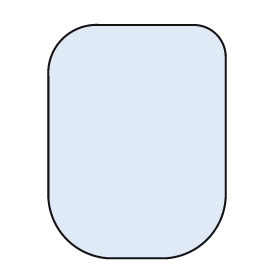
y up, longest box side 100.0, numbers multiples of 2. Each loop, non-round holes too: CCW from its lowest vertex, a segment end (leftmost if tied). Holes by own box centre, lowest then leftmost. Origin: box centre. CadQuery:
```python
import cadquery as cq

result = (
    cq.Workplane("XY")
    .moveTo(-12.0, -50.0)
    .lineTo(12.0, -50.0)
    .threePointArc((30.0, -42.0), (38.0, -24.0))
    .lineTo(38.0, 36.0)
    .threePointArc((34.0, 46.0), (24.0, 50.0))
    .lineTo(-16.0, 50.0)
    .threePointArc((-32.0, 44.0), (-38.0, 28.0))
    .lineTo(-38.0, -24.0)
    .threePointArc((-30.0, -42.0), (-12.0, -50.0))
    .close()
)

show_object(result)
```